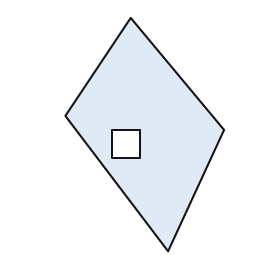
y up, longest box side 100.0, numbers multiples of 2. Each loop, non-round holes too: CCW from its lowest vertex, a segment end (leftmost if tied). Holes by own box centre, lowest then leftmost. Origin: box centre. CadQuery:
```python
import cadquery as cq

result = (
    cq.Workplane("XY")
    .moveTo(10.0, -50.0)
    .lineTo(34.0, 2.0)
    .lineTo(-6.0, 50.0)
    .lineTo(-34.0, 8.0)
    .close()
    .moveTo(-14.0, -10.0)
    .lineTo(-2.0, -10.0)
    .lineTo(-2.0, 2.0)
    .lineTo(-14.0, 2.0)
    .close()
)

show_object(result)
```